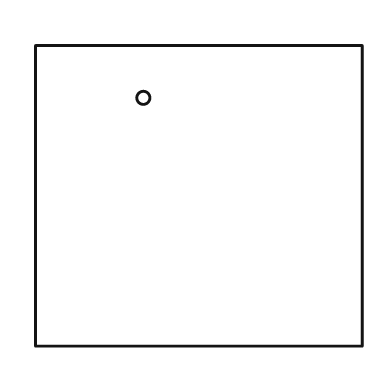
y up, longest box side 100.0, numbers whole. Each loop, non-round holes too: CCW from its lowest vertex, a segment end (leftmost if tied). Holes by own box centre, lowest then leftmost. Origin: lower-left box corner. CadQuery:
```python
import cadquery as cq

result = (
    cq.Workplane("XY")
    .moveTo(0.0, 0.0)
    .lineTo(100.0, 0.0)
    .lineTo(100.0, 92.0)
    .lineTo(0.0, 92.0)
    .close()
    .moveTo(33.0, 76.0)
    .circle(2.0)
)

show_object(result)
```